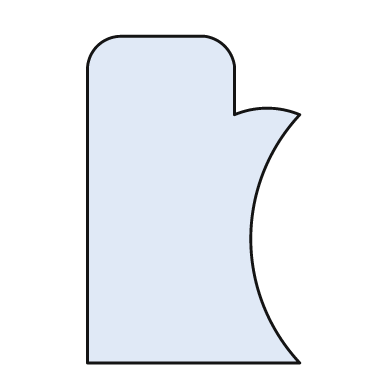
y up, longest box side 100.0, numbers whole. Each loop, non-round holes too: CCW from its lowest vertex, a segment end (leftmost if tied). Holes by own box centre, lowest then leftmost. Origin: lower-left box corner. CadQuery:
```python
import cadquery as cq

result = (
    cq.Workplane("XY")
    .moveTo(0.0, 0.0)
    .lineTo(65.0, 0.0)
    .threePointArc((50.0, 38.0), (65.0, 76.0))
    .threePointArc((55.0, 78.0), (45.0, 76.0))
    .lineTo(45.0, 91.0)
    .threePointArc((42.0, 97.0), (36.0, 100.0))
    .lineTo(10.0, 100.0)
    .threePointArc((3.0, 97.0), (0.0, 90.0))
    .close()
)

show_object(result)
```